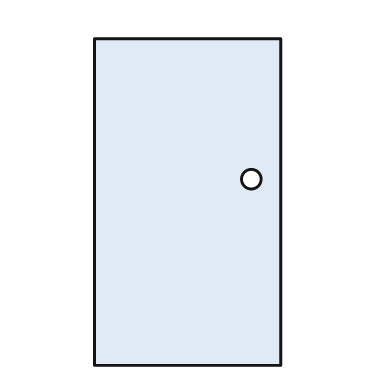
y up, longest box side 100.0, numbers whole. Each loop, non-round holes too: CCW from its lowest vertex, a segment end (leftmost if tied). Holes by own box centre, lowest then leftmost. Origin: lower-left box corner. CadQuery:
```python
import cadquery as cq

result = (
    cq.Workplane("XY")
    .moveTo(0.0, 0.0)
    .lineTo(57.0, 0.0)
    .lineTo(57.0, 100.0)
    .lineTo(0.0, 100.0)
    .close()
    .moveTo(48.0, 57.0)
    .circle(3.0)
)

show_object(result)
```